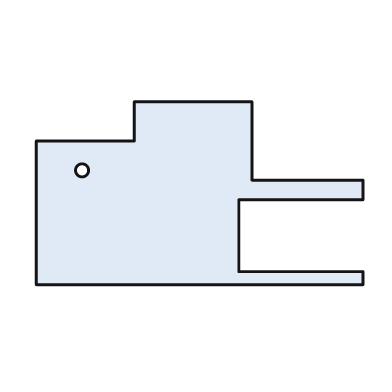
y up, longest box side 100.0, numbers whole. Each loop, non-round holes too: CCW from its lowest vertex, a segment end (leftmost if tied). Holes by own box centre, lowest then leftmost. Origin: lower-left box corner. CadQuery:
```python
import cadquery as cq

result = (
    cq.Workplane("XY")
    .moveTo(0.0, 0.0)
    .lineTo(100.0, 0.0)
    .lineTo(100.0, 4.0)
    .lineTo(62.0, 4.0)
    .lineTo(62.0, 26.0)
    .lineTo(100.0, 26.0)
    .lineTo(100.0, 32.0)
    .lineTo(66.0, 32.0)
    .lineTo(66.0, 56.0)
    .lineTo(30.0, 56.0)
    .lineTo(30.0, 44.0)
    .lineTo(0.0, 44.0)
    .close()
    .moveTo(14.0, 35.0)
    .circle(2.0)
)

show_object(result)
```